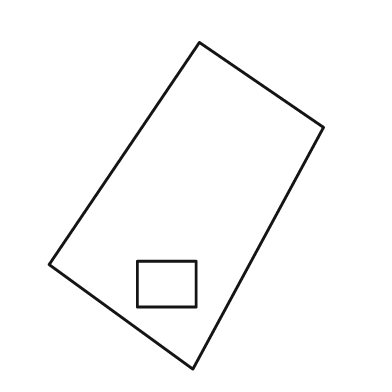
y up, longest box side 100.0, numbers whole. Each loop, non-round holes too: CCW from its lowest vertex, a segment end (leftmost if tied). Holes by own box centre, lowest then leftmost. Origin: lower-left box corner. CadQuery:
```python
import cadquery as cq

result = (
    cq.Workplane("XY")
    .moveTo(44.0, 0.0)
    .lineTo(84.0, 74.0)
    .lineTo(46.0, 100.0)
    .lineTo(0.0, 32.0)
    .close()
    .moveTo(27.0, 19.0)
    .lineTo(45.0, 19.0)
    .lineTo(45.0, 33.0)
    .lineTo(27.0, 33.0)
    .close()
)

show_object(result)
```